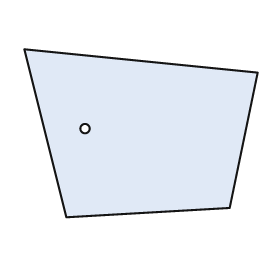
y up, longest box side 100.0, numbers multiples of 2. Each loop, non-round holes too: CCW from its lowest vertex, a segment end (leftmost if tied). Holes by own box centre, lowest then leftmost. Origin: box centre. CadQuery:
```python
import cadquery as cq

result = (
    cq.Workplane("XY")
    .moveTo(-32.0, -36.0)
    .lineTo(38.0, -32.0)
    .lineTo(50.0, 26.0)
    .lineTo(-50.0, 36.0)
    .close()
    .moveTo(-24.0, 2.0)
    .circle(2.0)
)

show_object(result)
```